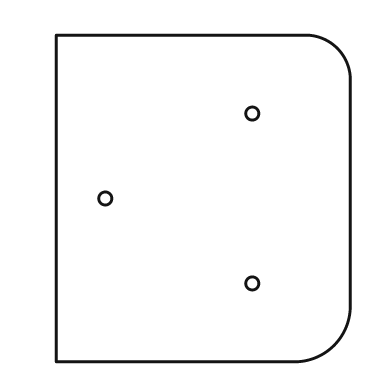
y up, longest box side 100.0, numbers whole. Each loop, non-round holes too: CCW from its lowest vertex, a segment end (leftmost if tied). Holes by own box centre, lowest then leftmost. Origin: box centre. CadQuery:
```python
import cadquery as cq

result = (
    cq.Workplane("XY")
    .moveTo(-45.0, -50.0)
    .lineTo(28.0, -50.0)
    .threePointArc((40.0, -45.0), (45.0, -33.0))
    .lineTo(45.0, 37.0)
    .threePointArc((41.0, 46.0), (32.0, 50.0))
    .lineTo(-45.0, 50.0)
    .close()
    .moveTo(15.0, -26.0)
    .circle(2.0)
    .moveTo(-30.0, 0.0)
    .circle(2.0)
    .moveTo(15.0, 26.0)
    .circle(2.0)
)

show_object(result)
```